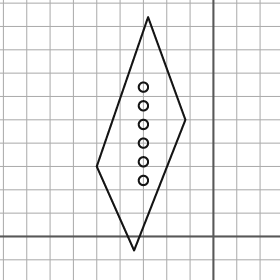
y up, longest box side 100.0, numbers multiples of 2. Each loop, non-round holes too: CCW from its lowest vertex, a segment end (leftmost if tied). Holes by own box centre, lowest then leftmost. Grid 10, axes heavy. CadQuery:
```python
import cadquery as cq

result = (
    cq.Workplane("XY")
    .moveTo(-34.0, -6.0)
    .lineTo(-12.0, 50.0)
    .lineTo(-28.0, 94.0)
    .lineTo(-50.0, 30.0)
    .close()
    .moveTo(-30.0, 24.0)
    .circle(2.0)
    .moveTo(-30.0, 32.0)
    .circle(2.0)
    .moveTo(-30.0, 40.0)
    .circle(2.0)
    .moveTo(-30.0, 48.0)
    .circle(2.0)
    .moveTo(-30.0, 56.0)
    .circle(2.0)
    .moveTo(-30.0, 64.0)
    .circle(2.0)
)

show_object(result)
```